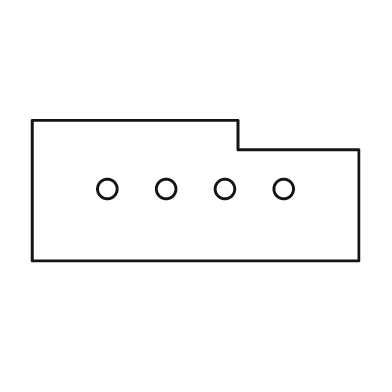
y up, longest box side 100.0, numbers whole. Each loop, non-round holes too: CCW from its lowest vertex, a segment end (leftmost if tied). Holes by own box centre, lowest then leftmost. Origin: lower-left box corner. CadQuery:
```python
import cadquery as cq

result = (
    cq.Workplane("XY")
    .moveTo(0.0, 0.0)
    .lineTo(100.0, 0.0)
    .lineTo(100.0, 34.0)
    .lineTo(63.0, 34.0)
    .lineTo(63.0, 43.0)
    .lineTo(0.0, 43.0)
    .close()
    .moveTo(23.0, 22.0)
    .circle(3.0)
    .moveTo(41.0, 22.0)
    .circle(3.0)
    .moveTo(59.0, 22.0)
    .circle(3.0)
    .moveTo(77.0, 22.0)
    .circle(3.0)
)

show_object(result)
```